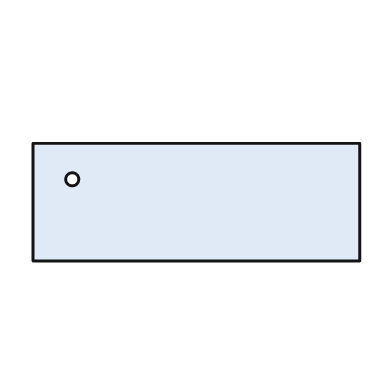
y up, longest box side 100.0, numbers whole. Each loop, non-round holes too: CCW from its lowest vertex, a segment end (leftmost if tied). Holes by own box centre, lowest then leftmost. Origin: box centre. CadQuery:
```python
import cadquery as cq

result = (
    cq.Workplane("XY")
    .moveTo(-50.0, -18.0)
    .lineTo(50.0, -18.0)
    .lineTo(50.0, 18.0)
    .lineTo(-50.0, 18.0)
    .close()
    .moveTo(-38.0, 7.0)
    .circle(2.0)
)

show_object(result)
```